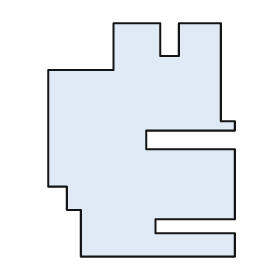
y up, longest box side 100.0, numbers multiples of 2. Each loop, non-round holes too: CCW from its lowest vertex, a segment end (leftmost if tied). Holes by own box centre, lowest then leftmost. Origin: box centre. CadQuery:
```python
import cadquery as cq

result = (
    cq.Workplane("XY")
    .moveTo(-26.0, -50.0)
    .lineTo(40.0, -50.0)
    .lineTo(40.0, -40.0)
    .lineTo(6.0, -40.0)
    .lineTo(6.0, -34.0)
    .lineTo(40.0, -34.0)
    .lineTo(40.0, -4.0)
    .lineTo(2.0, -4.0)
    .lineTo(2.0, 4.0)
    .lineTo(40.0, 4.0)
    .lineTo(40.0, 8.0)
    .lineTo(34.0, 8.0)
    .lineTo(34.0, 50.0)
    .lineTo(16.0, 50.0)
    .lineTo(16.0, 36.0)
    .lineTo(8.0, 36.0)
    .lineTo(8.0, 50.0)
    .lineTo(-12.0, 50.0)
    .lineTo(-12.0, 30.0)
    .lineTo(-40.0, 30.0)
    .lineTo(-40.0, -20.0)
    .lineTo(-32.0, -20.0)
    .lineTo(-32.0, -30.0)
    .lineTo(-26.0, -30.0)
    .close()
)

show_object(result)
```